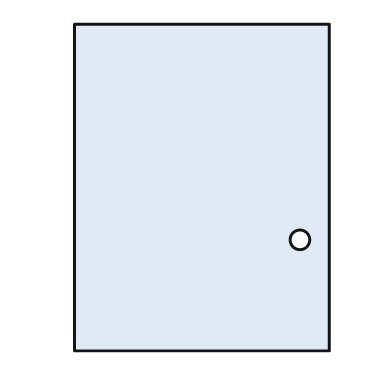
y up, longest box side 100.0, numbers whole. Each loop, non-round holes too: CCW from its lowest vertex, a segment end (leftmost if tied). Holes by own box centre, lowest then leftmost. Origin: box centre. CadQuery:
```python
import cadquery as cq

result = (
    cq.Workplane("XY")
    .moveTo(-39.0, -50.0)
    .lineTo(39.0, -50.0)
    .lineTo(39.0, 50.0)
    .lineTo(-39.0, 50.0)
    .close()
    .moveTo(30.0, -16.0)
    .circle(3.0)
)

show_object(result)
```